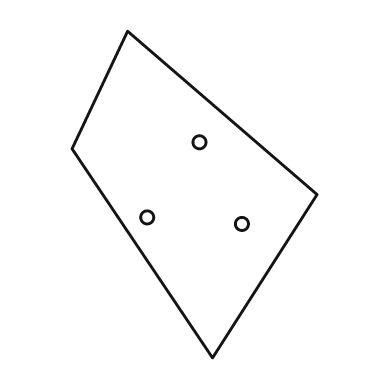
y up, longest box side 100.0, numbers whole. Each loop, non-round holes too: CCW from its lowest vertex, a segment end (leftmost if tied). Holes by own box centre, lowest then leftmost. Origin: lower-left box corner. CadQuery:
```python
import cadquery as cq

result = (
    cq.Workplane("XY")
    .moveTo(43.0, 0.0)
    .lineTo(75.0, 50.0)
    .lineTo(17.0, 100.0)
    .lineTo(0.0, 64.0)
    .close()
    .moveTo(52.0, 41.0)
    .circle(2.0)
    .moveTo(23.0, 43.0)
    .circle(2.0)
    .moveTo(39.0, 66.0)
    .circle(2.0)
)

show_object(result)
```